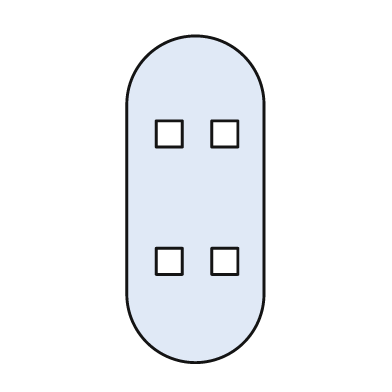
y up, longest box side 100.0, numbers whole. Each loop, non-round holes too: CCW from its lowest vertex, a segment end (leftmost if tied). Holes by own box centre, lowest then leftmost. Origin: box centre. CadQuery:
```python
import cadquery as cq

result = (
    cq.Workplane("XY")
    .moveTo(-21.0, -29.0)
    .threePointArc((0.0, -50.0), (21.0, -29.0))
    .lineTo(21.0, 29.0)
    .threePointArc((0.0, 50.0), (-21.0, 29.0))
    .close()
    .moveTo(-12.0, -23.0)
    .lineTo(-4.0, -23.0)
    .lineTo(-4.0, -15.0)
    .lineTo(-12.0, -15.0)
    .close()
    .moveTo(5.0, -23.0)
    .lineTo(13.0, -23.0)
    .lineTo(13.0, -15.0)
    .lineTo(5.0, -15.0)
    .close()
    .moveTo(-12.0, 16.0)
    .lineTo(-4.0, 16.0)
    .lineTo(-4.0, 24.0)
    .lineTo(-12.0, 24.0)
    .close()
    .moveTo(5.0, 16.0)
    .lineTo(13.0, 16.0)
    .lineTo(13.0, 24.0)
    .lineTo(5.0, 24.0)
    .close()
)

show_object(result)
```